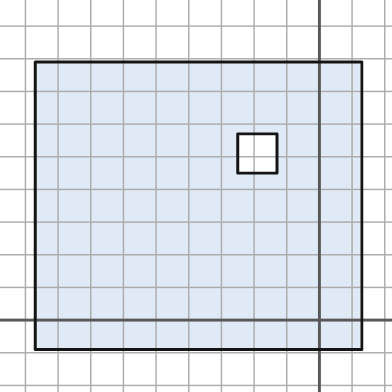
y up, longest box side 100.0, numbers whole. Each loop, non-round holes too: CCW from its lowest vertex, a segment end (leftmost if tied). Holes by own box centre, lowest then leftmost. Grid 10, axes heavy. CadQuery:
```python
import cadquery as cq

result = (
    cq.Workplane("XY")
    .moveTo(-87.0, -9.0)
    .lineTo(13.0, -9.0)
    .lineTo(13.0, 79.0)
    .lineTo(-87.0, 79.0)
    .close()
    .moveTo(-25.0, 45.0)
    .lineTo(-13.0, 45.0)
    .lineTo(-13.0, 57.0)
    .lineTo(-25.0, 57.0)
    .close()
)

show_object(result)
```